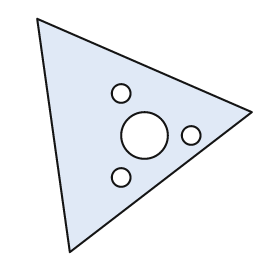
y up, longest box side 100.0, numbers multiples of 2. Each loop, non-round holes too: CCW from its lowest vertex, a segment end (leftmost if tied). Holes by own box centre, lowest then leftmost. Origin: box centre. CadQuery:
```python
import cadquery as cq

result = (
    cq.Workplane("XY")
    .moveTo(-32.0, -50.0)
    .lineTo(46.0, 10.0)
    .lineTo(-46.0, 50.0)
    .close()
    .moveTo(-10.0, -18.0)
    .circle(4.0)
    .moveTo(0.0, 0.0)
    .circle(10.0)
    .moveTo(20.0, 0.0)
    .circle(4.0)
    .moveTo(-10.0, 18.0)
    .circle(4.0)
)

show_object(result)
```